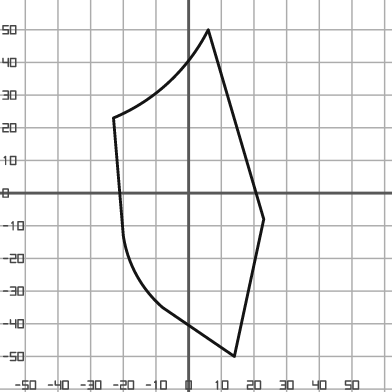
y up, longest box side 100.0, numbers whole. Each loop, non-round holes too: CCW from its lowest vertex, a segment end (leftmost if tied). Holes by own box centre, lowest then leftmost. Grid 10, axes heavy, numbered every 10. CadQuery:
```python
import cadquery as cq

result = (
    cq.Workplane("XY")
    .moveTo(14.0, -50.0)
    .lineTo(23.0, -8.0)
    .lineTo(6.0, 50.0)
    .threePointArc((-6.0, 34.0), (-23.0, 23.0))
    .lineTo(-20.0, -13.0)
    .threePointArc((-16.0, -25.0), (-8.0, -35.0))
    .close()
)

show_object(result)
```